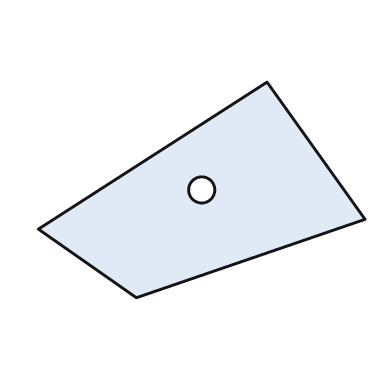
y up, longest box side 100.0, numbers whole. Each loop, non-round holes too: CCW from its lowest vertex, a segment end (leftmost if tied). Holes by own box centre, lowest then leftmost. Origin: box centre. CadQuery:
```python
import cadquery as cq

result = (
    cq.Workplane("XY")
    .moveTo(-20.0, -33.0)
    .lineTo(50.0, -9.0)
    .lineTo(20.0, 33.0)
    .lineTo(-50.0, -12.0)
    .close()
    .moveTo(0.0, 0.0)
    .circle(4.0)
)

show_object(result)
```